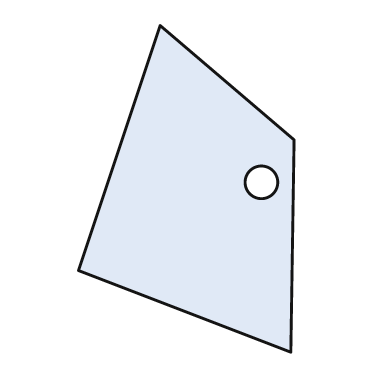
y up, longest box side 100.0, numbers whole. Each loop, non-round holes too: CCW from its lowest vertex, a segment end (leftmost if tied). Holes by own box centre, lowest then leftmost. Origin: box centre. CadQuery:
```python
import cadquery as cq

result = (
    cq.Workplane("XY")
    .moveTo(32.0, -50.0)
    .lineTo(33.0, 15.0)
    .lineTo(-8.0, 50.0)
    .lineTo(-33.0, -25.0)
    .close()
    .moveTo(23.0, 2.0)
    .circle(5.0)
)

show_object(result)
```